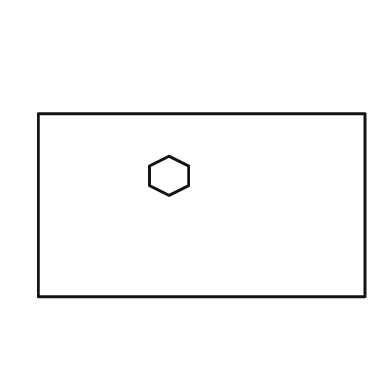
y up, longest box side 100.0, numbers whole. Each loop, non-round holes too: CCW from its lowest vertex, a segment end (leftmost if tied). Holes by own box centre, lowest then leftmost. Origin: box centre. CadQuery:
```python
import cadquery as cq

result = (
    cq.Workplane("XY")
    .moveTo(-50.0, -28.0)
    .lineTo(50.0, -28.0)
    .lineTo(50.0, 28.0)
    .lineTo(-50.0, 28.0)
    .close()
    .moveTo(-10.0, 3.0)
    .lineTo(-4.0, 6.0)
    .lineTo(-4.0, 12.0)
    .lineTo(-10.0, 15.0)
    .lineTo(-16.0, 12.0)
    .lineTo(-16.0, 6.0)
    .close()
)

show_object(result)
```